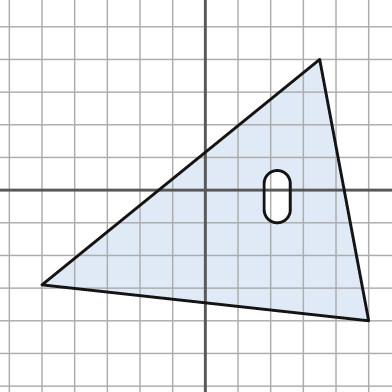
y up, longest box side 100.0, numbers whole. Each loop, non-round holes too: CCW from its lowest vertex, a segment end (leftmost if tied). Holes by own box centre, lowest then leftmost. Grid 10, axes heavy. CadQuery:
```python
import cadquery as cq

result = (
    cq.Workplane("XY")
    .moveTo(50.0, -40.0)
    .lineTo(35.0, 40.0)
    .lineTo(-50.0, -29.0)
    .close()
    .moveTo(18.0, -6.0)
    .threePointArc((22.0, -10.0), (26.0, -6.0))
    .lineTo(26.0, 2.0)
    .threePointArc((22.0, 6.0), (18.0, 2.0))
    .close()
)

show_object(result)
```